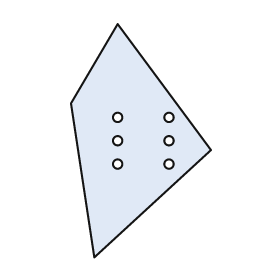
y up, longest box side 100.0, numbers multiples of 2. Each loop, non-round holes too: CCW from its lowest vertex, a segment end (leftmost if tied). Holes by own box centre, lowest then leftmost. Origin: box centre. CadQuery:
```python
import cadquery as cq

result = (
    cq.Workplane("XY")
    .moveTo(-20.0, -50.0)
    .lineTo(30.0, -4.0)
    .lineTo(-10.0, 50.0)
    .lineTo(-30.0, 16.0)
    .close()
    .moveTo(-10.0, -10.0)
    .circle(2.0)
    .moveTo(12.0, -10.0)
    .circle(2.0)
    .moveTo(-10.0, 0.0)
    .circle(2.0)
    .moveTo(12.0, 0.0)
    .circle(2.0)
    .moveTo(-10.0, 10.0)
    .circle(2.0)
    .moveTo(12.0, 10.0)
    .circle(2.0)
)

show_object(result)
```